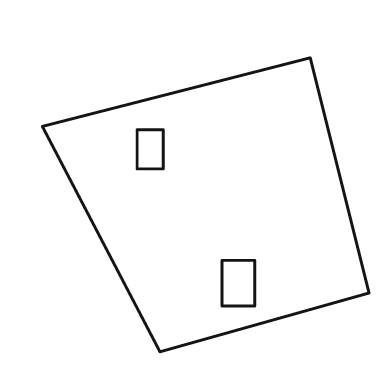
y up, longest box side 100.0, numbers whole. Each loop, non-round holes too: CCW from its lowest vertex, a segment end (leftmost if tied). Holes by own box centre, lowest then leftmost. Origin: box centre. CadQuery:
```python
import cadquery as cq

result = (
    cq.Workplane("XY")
    .moveTo(-14.0, -45.0)
    .lineTo(50.0, -27.0)
    .lineTo(32.0, 45.0)
    .lineTo(-50.0, 24.0)
    .close()
    .moveTo(5.0, -31.0)
    .lineTo(15.0, -31.0)
    .lineTo(15.0, -17.0)
    .lineTo(5.0, -17.0)
    .close()
    .moveTo(-21.0, 11.0)
    .lineTo(-13.0, 11.0)
    .lineTo(-13.0, 23.0)
    .lineTo(-21.0, 23.0)
    .close()
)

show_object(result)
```